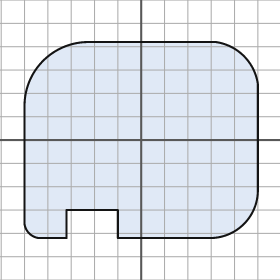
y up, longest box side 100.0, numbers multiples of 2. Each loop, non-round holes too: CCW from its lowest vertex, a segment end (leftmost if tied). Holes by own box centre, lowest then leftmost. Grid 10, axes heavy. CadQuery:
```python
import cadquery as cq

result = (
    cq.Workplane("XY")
    .moveTo(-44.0, -42.0)
    .lineTo(-32.0, -42.0)
    .lineTo(-32.0, -30.0)
    .lineTo(-10.0, -30.0)
    .lineTo(-10.0, -42.0)
    .lineTo(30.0, -42.0)
    .threePointArc((44.0, -36.0), (50.0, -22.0))
    .lineTo(50.0, 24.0)
    .threePointArc((44.0, 36.0), (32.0, 42.0))
    .lineTo(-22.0, 42.0)
    .threePointArc((-42.0, 34.0), (-50.0, 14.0))
    .lineTo(-50.0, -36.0)
    .threePointArc((-48.0, -40.0), (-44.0, -42.0))
    .close()
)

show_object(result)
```